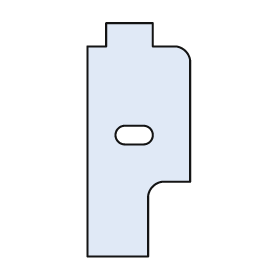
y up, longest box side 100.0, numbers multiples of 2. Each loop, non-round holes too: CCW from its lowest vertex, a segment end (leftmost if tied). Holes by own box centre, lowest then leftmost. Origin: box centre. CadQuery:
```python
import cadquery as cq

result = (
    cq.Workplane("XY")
    .moveTo(-22.0, -50.0)
    .lineTo(4.0, -50.0)
    .lineTo(4.0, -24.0)
    .threePointArc((6.0, -20.0), (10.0, -18.0))
    .lineTo(22.0, -18.0)
    .lineTo(22.0, 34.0)
    .threePointArc((20.0, 38.0), (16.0, 40.0))
    .lineTo(6.0, 40.0)
    .lineTo(6.0, 50.0)
    .lineTo(-14.0, 50.0)
    .lineTo(-14.0, 40.0)
    .lineTo(-22.0, 40.0)
    .close()
    .moveTo(-6.0, -2.0)
    .lineTo(2.0, -2.0)
    .threePointArc((6.0, 2.0), (2.0, 6.0))
    .lineTo(-6.0, 6.0)
    .threePointArc((-10.0, 2.0), (-6.0, -2.0))
    .close()
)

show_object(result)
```